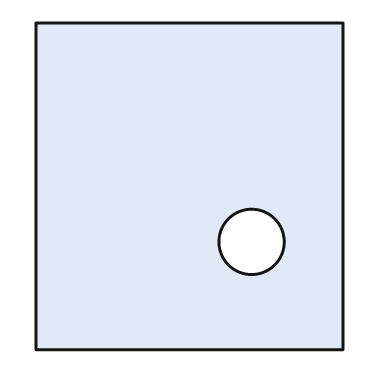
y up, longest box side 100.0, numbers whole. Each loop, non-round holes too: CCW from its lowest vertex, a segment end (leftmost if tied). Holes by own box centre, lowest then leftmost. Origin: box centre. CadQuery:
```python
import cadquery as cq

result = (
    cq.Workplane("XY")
    .moveTo(-47.0, -50.0)
    .lineTo(47.0, -50.0)
    .lineTo(47.0, 50.0)
    .lineTo(-47.0, 50.0)
    .close()
    .moveTo(19.0, -17.0)
    .circle(10.0)
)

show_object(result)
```